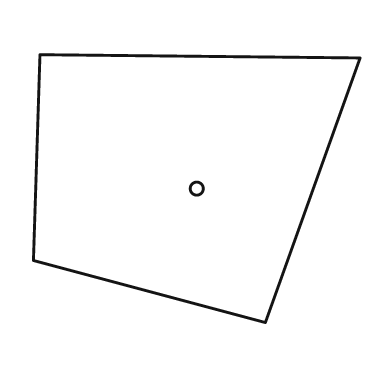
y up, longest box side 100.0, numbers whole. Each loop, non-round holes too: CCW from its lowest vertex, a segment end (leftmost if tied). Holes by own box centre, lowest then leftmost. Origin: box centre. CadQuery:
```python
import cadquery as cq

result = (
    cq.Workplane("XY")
    .moveTo(21.0, -41.0)
    .lineTo(50.0, 40.0)
    .lineTo(-48.0, 41.0)
    .lineTo(-50.0, -22.0)
    .close()
    .moveTo(0.0, 0.0)
    .circle(2.0)
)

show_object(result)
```